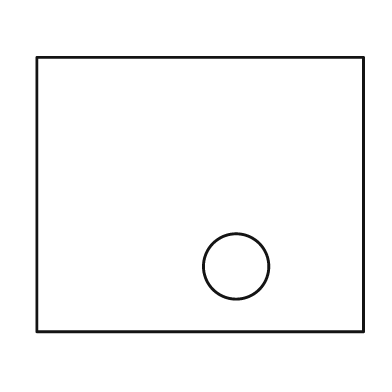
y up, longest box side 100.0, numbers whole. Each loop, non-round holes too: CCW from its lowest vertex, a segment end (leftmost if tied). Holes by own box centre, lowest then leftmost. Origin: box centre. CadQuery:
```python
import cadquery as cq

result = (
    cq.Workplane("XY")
    .moveTo(-50.0, -42.0)
    .lineTo(50.0, -42.0)
    .lineTo(50.0, 42.0)
    .lineTo(-50.0, 42.0)
    .close()
    .moveTo(11.0, -22.0)
    .circle(10.0)
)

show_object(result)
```